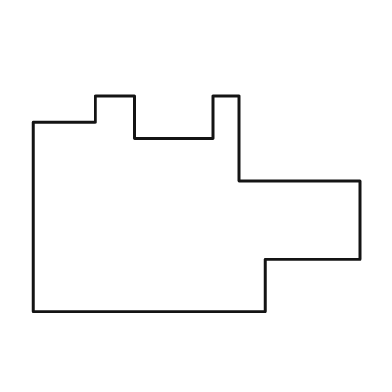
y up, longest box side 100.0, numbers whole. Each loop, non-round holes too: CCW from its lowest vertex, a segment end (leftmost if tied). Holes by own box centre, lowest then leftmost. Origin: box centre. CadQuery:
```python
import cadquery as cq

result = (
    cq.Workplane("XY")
    .moveTo(-50.0, -33.0)
    .lineTo(21.0, -33.0)
    .lineTo(21.0, -17.0)
    .lineTo(50.0, -17.0)
    .lineTo(50.0, 7.0)
    .lineTo(13.0, 7.0)
    .lineTo(13.0, 33.0)
    .lineTo(5.0, 33.0)
    .lineTo(5.0, 20.0)
    .lineTo(-19.0, 20.0)
    .lineTo(-19.0, 33.0)
    .lineTo(-31.0, 33.0)
    .lineTo(-31.0, 25.0)
    .lineTo(-50.0, 25.0)
    .close()
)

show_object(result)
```